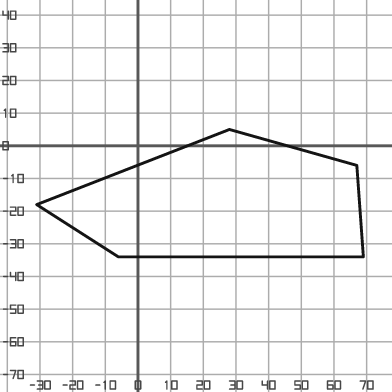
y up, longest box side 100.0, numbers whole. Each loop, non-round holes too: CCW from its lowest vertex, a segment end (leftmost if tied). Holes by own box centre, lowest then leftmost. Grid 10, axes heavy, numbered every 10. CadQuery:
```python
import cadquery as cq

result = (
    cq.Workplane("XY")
    .moveTo(-6.0, -34.0)
    .lineTo(69.0, -34.0)
    .lineTo(67.0, -6.0)
    .lineTo(28.0, 5.0)
    .lineTo(-31.0, -18.0)
    .close()
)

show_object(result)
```